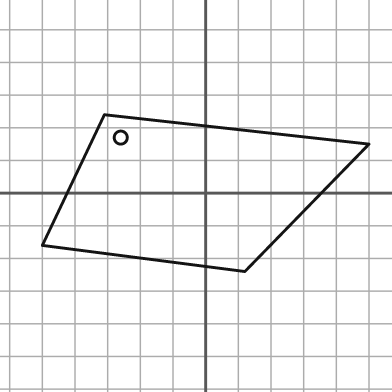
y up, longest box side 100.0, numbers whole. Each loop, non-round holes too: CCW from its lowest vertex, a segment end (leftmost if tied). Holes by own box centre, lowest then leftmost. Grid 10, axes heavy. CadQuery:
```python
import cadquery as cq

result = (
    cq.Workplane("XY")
    .moveTo(12.0, -24.0)
    .lineTo(50.0, 15.0)
    .lineTo(-31.0, 24.0)
    .lineTo(-50.0, -16.0)
    .close()
    .moveTo(-26.0, 17.0)
    .circle(2.0)
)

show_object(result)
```